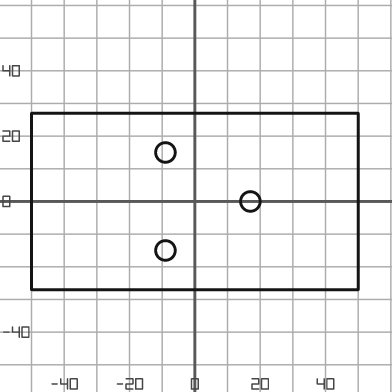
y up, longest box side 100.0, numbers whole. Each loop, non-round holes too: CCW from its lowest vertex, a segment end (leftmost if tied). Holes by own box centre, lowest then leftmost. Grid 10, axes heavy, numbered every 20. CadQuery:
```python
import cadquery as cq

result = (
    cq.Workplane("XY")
    .moveTo(-50.0, -27.0)
    .lineTo(50.0, -27.0)
    .lineTo(50.0, 27.0)
    .lineTo(-50.0, 27.0)
    .close()
    .moveTo(-9.0, -15.0)
    .circle(3.0)
    .moveTo(17.0, 0.0)
    .circle(3.0)
    .moveTo(-9.0, 15.0)
    .circle(3.0)
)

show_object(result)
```